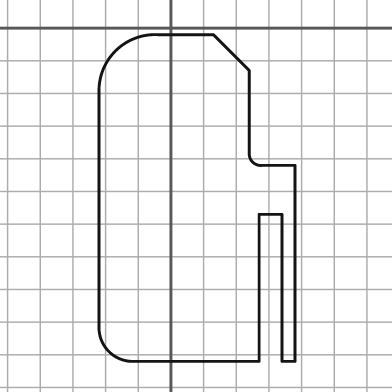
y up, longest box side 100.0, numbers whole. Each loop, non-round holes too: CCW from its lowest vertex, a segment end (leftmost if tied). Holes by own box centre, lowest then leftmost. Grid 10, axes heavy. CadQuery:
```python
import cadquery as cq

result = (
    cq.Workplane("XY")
    .moveTo(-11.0, -102.0)
    .lineTo(27.0, -102.0)
    .lineTo(27.0, -57.0)
    .lineTo(34.0, -57.0)
    .lineTo(34.0, -102.0)
    .lineTo(38.0, -102.0)
    .lineTo(38.0, -42.0)
    .lineTo(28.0, -42.0)
    .threePointArc((25.0, -41.0), (24.0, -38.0))
    .lineTo(24.0, -13.0)
    .lineTo(13.0, -2.0)
    .lineTo(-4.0, -2.0)
    .threePointArc((-17.0, -7.0), (-22.0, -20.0))
    .lineTo(-22.0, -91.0)
    .threePointArc((-19.0, -99.0), (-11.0, -102.0))
    .close()
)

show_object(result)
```